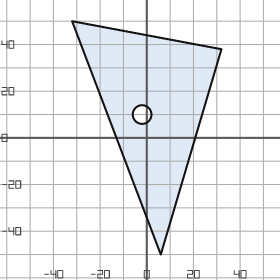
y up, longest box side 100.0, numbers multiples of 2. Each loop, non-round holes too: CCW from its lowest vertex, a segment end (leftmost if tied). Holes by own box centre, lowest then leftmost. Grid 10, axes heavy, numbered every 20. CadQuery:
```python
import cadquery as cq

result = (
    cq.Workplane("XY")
    .moveTo(6.0, -50.0)
    .lineTo(32.0, 38.0)
    .lineTo(-32.0, 50.0)
    .close()
    .moveTo(-2.0, 10.0)
    .circle(4.0)
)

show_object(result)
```